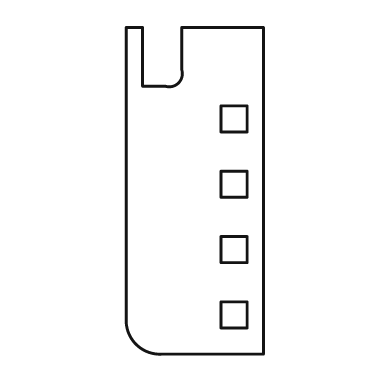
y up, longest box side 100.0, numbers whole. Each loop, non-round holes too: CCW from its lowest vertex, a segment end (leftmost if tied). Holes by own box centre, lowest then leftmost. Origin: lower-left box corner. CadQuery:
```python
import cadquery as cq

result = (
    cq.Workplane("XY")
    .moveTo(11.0, 0.0)
    .lineTo(42.0, 0.0)
    .lineTo(42.0, 100.0)
    .lineTo(17.0, 100.0)
    .lineTo(17.0, 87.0)
    .threePointArc((16.0, 83.0), (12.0, 82.0))
    .lineTo(5.0, 82.0)
    .lineTo(5.0, 100.0)
    .lineTo(0.0, 100.0)
    .lineTo(0.0, 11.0)
    .threePointArc((3.0, 3.0), (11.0, 0.0))
    .close()
    .moveTo(29.0, 8.0)
    .lineTo(37.0, 8.0)
    .lineTo(37.0, 16.0)
    .lineTo(29.0, 16.0)
    .close()
    .moveTo(29.0, 28.0)
    .lineTo(37.0, 28.0)
    .lineTo(37.0, 36.0)
    .lineTo(29.0, 36.0)
    .close()
    .moveTo(29.0, 48.0)
    .lineTo(37.0, 48.0)
    .lineTo(37.0, 56.0)
    .lineTo(29.0, 56.0)
    .close()
    .moveTo(29.0, 68.0)
    .lineTo(37.0, 68.0)
    .lineTo(37.0, 76.0)
    .lineTo(29.0, 76.0)
    .close()
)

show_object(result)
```